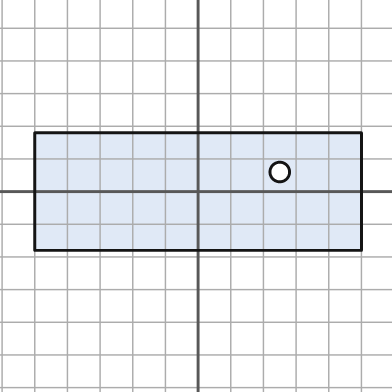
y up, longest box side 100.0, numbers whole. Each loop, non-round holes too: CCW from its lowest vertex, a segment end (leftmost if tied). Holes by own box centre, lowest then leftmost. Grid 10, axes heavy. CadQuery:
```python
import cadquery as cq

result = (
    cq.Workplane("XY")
    .moveTo(-50.0, -18.0)
    .lineTo(50.0, -18.0)
    .lineTo(50.0, 18.0)
    .lineTo(-50.0, 18.0)
    .close()
    .moveTo(25.0, 6.0)
    .circle(3.0)
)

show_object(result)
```